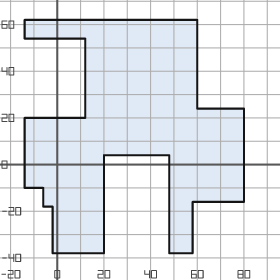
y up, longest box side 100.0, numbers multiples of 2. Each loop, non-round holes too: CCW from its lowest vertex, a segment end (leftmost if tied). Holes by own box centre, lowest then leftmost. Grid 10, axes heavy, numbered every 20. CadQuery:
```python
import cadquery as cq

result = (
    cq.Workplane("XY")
    .moveTo(-2.0, -38.0)
    .lineTo(20.0, -38.0)
    .lineTo(20.0, 4.0)
    .lineTo(48.0, 4.0)
    .lineTo(48.0, -38.0)
    .lineTo(58.0, -38.0)
    .lineTo(58.0, -16.0)
    .lineTo(80.0, -16.0)
    .lineTo(80.0, 24.0)
    .lineTo(60.0, 24.0)
    .lineTo(60.0, 62.0)
    .lineTo(-14.0, 62.0)
    .lineTo(-14.0, 54.0)
    .lineTo(12.0, 54.0)
    .lineTo(12.0, 20.0)
    .lineTo(-14.0, 20.0)
    .lineTo(-14.0, -10.0)
    .lineTo(-6.0, -10.0)
    .lineTo(-6.0, -18.0)
    .lineTo(-2.0, -18.0)
    .close()
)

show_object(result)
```